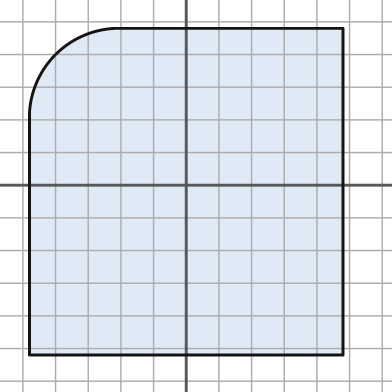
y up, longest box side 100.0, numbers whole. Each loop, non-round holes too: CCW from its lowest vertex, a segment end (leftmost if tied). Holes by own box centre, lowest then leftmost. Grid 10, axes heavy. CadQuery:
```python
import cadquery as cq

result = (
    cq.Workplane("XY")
    .moveTo(-48.0, -52.0)
    .lineTo(48.0, -52.0)
    .lineTo(48.0, 48.0)
    .lineTo(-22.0, 48.0)
    .threePointArc((-40.0, 40.0), (-48.0, 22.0))
    .close()
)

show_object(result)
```